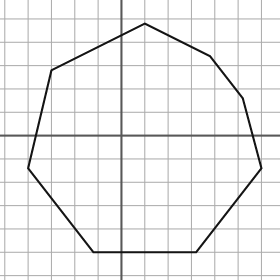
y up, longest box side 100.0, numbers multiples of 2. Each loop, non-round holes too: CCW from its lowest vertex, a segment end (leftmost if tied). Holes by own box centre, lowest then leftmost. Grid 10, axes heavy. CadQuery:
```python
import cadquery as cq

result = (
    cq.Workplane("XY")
    .moveTo(-12.0, -50.0)
    .lineTo(32.0, -50.0)
    .lineTo(60.0, -14.0)
    .lineTo(52.0, 16.0)
    .lineTo(38.0, 34.0)
    .lineTo(10.0, 48.0)
    .lineTo(-30.0, 28.0)
    .lineTo(-40.0, -14.0)
    .close()
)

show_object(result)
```